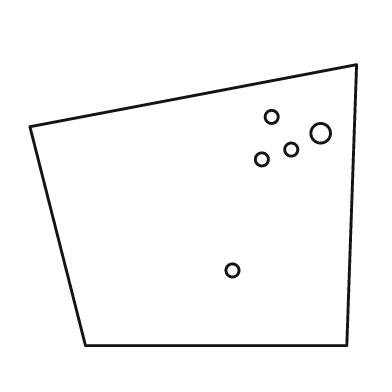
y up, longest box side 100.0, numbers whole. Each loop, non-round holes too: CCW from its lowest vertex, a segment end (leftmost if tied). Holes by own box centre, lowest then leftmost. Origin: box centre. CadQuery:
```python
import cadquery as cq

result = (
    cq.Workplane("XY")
    .moveTo(-33.0, -43.0)
    .lineTo(47.0, -43.0)
    .lineTo(50.0, 43.0)
    .lineTo(-50.0, 24.0)
    .close()
    .moveTo(12.0, -20.0)
    .circle(2.0)
    .moveTo(21.0, 14.0)
    .circle(2.0)
    .moveTo(30.0, 17.0)
    .circle(2.0)
    .moveTo(39.0, 22.0)
    .circle(3.0)
    .moveTo(24.0, 27.0)
    .circle(2.0)
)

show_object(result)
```